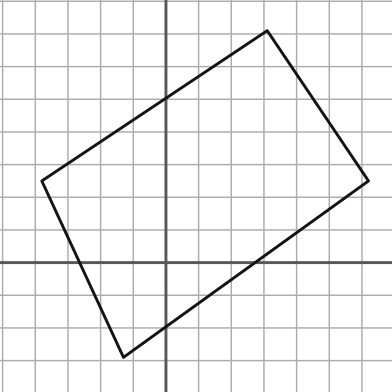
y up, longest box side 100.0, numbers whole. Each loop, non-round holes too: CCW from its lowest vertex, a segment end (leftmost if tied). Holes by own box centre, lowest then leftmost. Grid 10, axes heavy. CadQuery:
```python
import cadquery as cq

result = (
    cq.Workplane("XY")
    .moveTo(-13.0, -29.0)
    .lineTo(62.0, 25.0)
    .lineTo(31.0, 71.0)
    .lineTo(-38.0, 25.0)
    .close()
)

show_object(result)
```